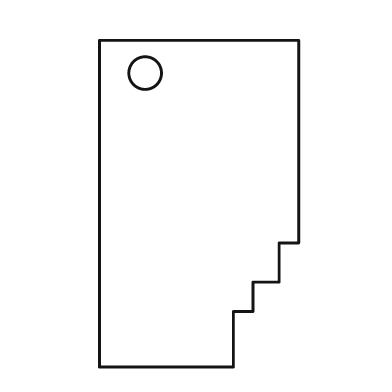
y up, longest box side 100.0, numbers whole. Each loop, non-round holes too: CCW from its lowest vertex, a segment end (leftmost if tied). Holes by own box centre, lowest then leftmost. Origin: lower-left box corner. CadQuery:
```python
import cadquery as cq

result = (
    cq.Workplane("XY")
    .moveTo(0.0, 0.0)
    .lineTo(41.0, 0.0)
    .lineTo(41.0, 17.0)
    .lineTo(47.0, 17.0)
    .lineTo(47.0, 26.0)
    .lineTo(55.0, 26.0)
    .lineTo(55.0, 38.0)
    .lineTo(61.0, 38.0)
    .lineTo(61.0, 100.0)
    .lineTo(0.0, 100.0)
    .close()
    .moveTo(14.0, 90.0)
    .circle(5.0)
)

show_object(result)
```